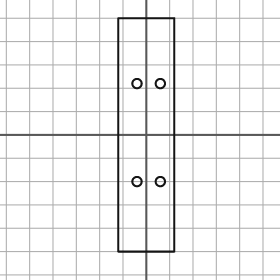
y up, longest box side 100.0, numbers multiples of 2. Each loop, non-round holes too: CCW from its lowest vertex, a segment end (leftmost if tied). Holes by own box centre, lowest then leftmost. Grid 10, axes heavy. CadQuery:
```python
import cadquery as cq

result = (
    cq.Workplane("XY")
    .moveTo(-12.0, -50.0)
    .lineTo(12.0, -50.0)
    .lineTo(12.0, 50.0)
    .lineTo(-12.0, 50.0)
    .close()
    .moveTo(-4.0, -20.0)
    .circle(2.0)
    .moveTo(6.0, -20.0)
    .circle(2.0)
    .moveTo(-4.0, 22.0)
    .circle(2.0)
    .moveTo(6.0, 22.0)
    .circle(2.0)
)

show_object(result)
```